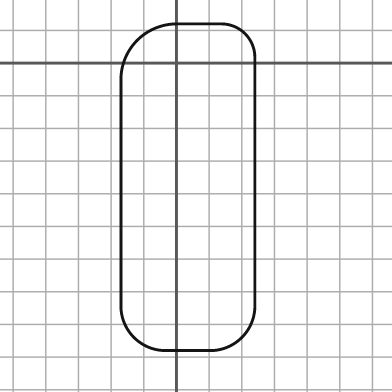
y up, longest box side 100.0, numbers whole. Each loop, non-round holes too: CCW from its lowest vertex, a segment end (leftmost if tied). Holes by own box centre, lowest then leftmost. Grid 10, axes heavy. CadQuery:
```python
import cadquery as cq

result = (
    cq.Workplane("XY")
    .moveTo(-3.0, -88.0)
    .lineTo(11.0, -88.0)
    .threePointArc((20.0, -84.0), (24.0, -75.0))
    .lineTo(24.0, 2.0)
    .threePointArc((21.0, 9.0), (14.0, 12.0))
    .lineTo(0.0, 12.0)
    .threePointArc((-12.0, 7.0), (-17.0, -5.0))
    .lineTo(-17.0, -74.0)
    .threePointArc((-13.0, -84.0), (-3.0, -88.0))
    .close()
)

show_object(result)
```